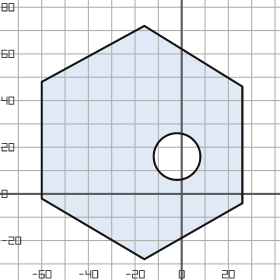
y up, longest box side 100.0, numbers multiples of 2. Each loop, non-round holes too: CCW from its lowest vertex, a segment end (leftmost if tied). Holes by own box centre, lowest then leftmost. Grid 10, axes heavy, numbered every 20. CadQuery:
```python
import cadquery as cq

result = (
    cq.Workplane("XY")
    .moveTo(-16.0, -28.0)
    .lineTo(26.0, -4.0)
    .lineTo(26.0, 46.0)
    .lineTo(-16.0, 72.0)
    .lineTo(-60.0, 48.0)
    .lineTo(-60.0, -2.0)
    .close()
    .moveTo(-2.0, 16.0)
    .circle(10.0)
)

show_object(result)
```